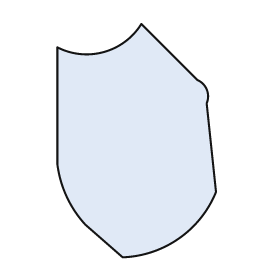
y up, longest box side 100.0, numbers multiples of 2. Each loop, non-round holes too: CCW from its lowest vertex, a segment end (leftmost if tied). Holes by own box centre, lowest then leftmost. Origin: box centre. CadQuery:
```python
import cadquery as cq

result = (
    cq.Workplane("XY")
    .moveTo(-6.0, -50.0)
    .threePointArc((18.0, -42.0), (34.0, -22.0))
    .lineTo(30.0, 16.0)
    .threePointArc((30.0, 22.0), (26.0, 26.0))
    .lineTo(2.0, 50.0)
    .threePointArc((-14.0, 38.0), (-34.0, 40.0))
    .lineTo(-34.0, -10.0)
    .threePointArc((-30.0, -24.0), (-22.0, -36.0))
    .close()
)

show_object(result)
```